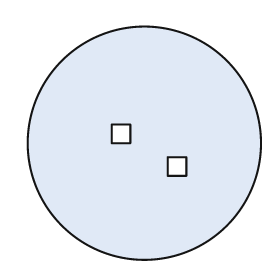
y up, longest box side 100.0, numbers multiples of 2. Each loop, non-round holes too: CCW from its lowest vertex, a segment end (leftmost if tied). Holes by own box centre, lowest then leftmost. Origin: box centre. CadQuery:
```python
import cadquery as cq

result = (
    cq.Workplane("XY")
    .moveTo(0.0, 0.0)
    .circle(50.0)
    .moveTo(10.0, -14.0)
    .lineTo(18.0, -14.0)
    .lineTo(18.0, -6.0)
    .lineTo(10.0, -6.0)
    .close()
    .moveTo(-14.0, 0.0)
    .lineTo(-6.0, 0.0)
    .lineTo(-6.0, 8.0)
    .lineTo(-14.0, 8.0)
    .close()
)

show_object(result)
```